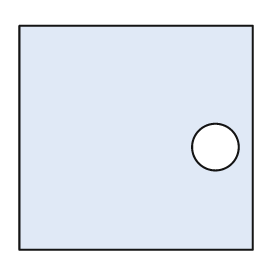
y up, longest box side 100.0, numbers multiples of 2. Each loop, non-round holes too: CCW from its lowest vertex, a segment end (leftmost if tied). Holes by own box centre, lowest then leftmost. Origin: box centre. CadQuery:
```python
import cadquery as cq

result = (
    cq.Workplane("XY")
    .moveTo(-50.0, -48.0)
    .lineTo(50.0, -48.0)
    .lineTo(50.0, 48.0)
    .lineTo(-50.0, 48.0)
    .close()
    .moveTo(34.0, -4.0)
    .circle(10.0)
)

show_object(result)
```